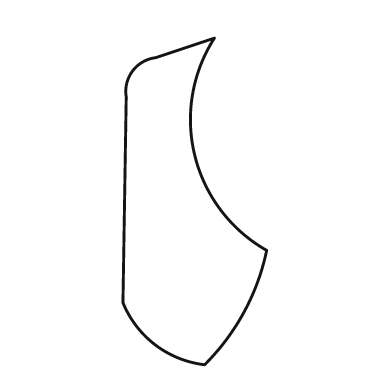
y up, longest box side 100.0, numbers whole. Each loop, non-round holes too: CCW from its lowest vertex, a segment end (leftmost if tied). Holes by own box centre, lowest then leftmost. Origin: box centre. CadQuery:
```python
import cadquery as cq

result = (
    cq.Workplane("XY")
    .moveTo(3.0, -50.0)
    .threePointArc((15.0, -34.0), (22.0, -15.0))
    .threePointArc((0.0, 14.0), (6.0, 50.0))
    .lineTo(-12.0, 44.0)
    .threePointArc((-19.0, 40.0), (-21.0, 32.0))
    .lineTo(-22.0, -31.0)
    .threePointArc((-12.0, -44.0), (3.0, -50.0))
    .close()
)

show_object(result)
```